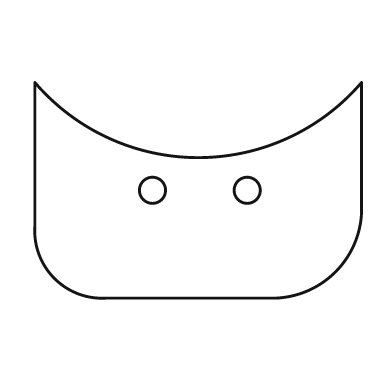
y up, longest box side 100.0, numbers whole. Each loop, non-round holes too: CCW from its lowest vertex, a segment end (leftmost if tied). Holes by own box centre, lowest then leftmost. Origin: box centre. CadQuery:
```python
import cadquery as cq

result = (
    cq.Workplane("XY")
    .moveTo(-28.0, -33.0)
    .lineTo(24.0, -33.0)
    .threePointArc((42.0, -25.0), (50.0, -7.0))
    .lineTo(50.0, 33.0)
    .threePointArc((0.0, 10.0), (-50.0, 33.0))
    .lineTo(-50.0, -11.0)
    .threePointArc((-44.0, -27.0), (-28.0, -33.0))
    .close()
    .moveTo(-14.0, 0.0)
    .circle(4.0)
    .moveTo(15.0, 0.0)
    .circle(4.0)
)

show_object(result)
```